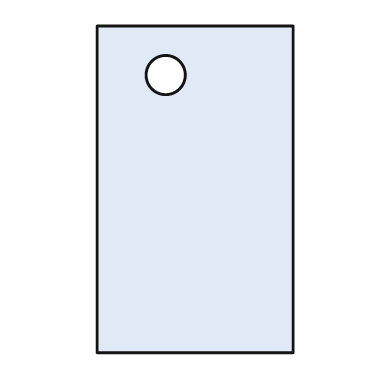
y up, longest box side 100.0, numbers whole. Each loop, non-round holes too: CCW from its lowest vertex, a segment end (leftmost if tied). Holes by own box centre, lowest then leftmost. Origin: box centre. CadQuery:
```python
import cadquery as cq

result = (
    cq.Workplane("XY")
    .moveTo(-30.0, -50.0)
    .lineTo(30.0, -50.0)
    .lineTo(30.0, 50.0)
    .lineTo(-30.0, 50.0)
    .close()
    .moveTo(-9.0, 35.0)
    .circle(6.0)
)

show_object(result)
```